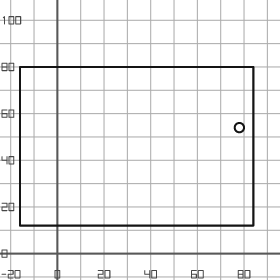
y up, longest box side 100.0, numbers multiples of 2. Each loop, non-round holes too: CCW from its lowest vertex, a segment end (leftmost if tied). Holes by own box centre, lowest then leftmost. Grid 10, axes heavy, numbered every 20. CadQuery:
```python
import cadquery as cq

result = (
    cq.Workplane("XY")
    .moveTo(-16.0, 12.0)
    .lineTo(84.0, 12.0)
    .lineTo(84.0, 80.0)
    .lineTo(-16.0, 80.0)
    .close()
    .moveTo(78.0, 54.0)
    .circle(2.0)
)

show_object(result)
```